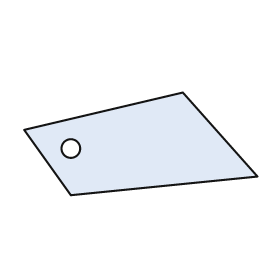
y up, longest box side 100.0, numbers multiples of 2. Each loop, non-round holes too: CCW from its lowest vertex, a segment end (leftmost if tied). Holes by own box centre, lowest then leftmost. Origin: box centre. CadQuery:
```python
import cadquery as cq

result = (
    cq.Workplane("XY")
    .moveTo(-30.0, -22.0)
    .lineTo(50.0, -14.0)
    .lineTo(18.0, 22.0)
    .lineTo(-50.0, 6.0)
    .close()
    .moveTo(-30.0, -2.0)
    .circle(4.0)
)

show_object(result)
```